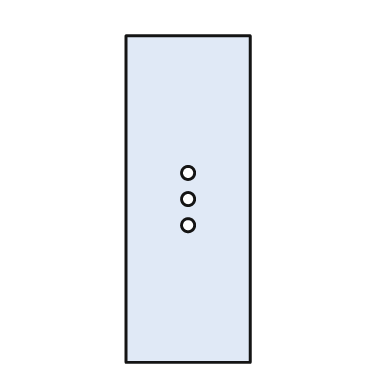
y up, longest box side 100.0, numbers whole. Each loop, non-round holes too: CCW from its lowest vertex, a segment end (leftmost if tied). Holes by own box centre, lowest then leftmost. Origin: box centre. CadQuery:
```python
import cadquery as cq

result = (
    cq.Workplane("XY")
    .moveTo(-19.0, -50.0)
    .lineTo(19.0, -50.0)
    .lineTo(19.0, 50.0)
    .lineTo(-19.0, 50.0)
    .close()
    .moveTo(0.0, -8.0)
    .circle(2.0)
    .moveTo(0.0, 0.0)
    .circle(2.0)
    .moveTo(0.0, 8.0)
    .circle(2.0)
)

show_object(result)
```